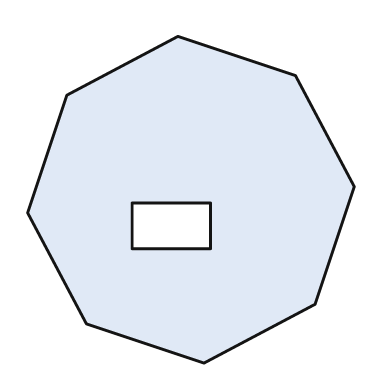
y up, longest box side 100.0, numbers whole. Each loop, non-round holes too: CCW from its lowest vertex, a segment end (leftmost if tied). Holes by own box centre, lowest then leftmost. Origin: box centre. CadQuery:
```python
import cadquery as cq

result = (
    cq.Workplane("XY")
    .moveTo(4.0, -50.0)
    .lineTo(38.0, -32.0)
    .lineTo(50.0, 4.0)
    .lineTo(32.0, 38.0)
    .lineTo(-4.0, 50.0)
    .lineTo(-38.0, 32.0)
    .lineTo(-50.0, -4.0)
    .lineTo(-32.0, -38.0)
    .close()
    .moveTo(-18.0, -15.0)
    .lineTo(6.0, -15.0)
    .lineTo(6.0, -1.0)
    .lineTo(-18.0, -1.0)
    .close()
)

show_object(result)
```